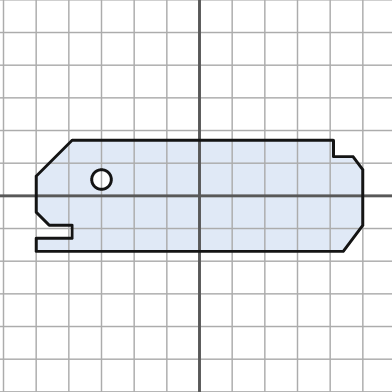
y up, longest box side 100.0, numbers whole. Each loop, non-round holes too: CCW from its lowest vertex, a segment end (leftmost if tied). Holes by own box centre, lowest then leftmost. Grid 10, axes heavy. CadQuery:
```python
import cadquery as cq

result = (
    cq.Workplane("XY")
    .moveTo(-50.0, -17.0)
    .lineTo(44.0, -17.0)
    .lineTo(50.0, -9.0)
    .lineTo(50.0, 8.0)
    .lineTo(47.0, 12.0)
    .lineTo(41.0, 12.0)
    .lineTo(41.0, 17.0)
    .lineTo(-39.0, 17.0)
    .lineTo(-50.0, 6.0)
    .lineTo(-50.0, -5.0)
    .lineTo(-46.0, -9.0)
    .lineTo(-39.0, -9.0)
    .lineTo(-39.0, -13.0)
    .lineTo(-50.0, -13.0)
    .close()
    .moveTo(-30.0, 5.0)
    .circle(3.0)
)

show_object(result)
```